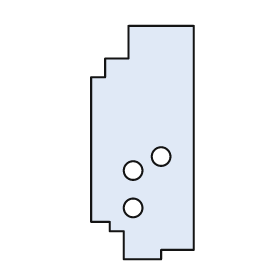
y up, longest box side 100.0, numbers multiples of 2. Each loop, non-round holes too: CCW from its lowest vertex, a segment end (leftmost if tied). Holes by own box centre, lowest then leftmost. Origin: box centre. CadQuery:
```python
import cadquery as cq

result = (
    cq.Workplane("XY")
    .moveTo(-8.0, -50.0)
    .lineTo(8.0, -50.0)
    .lineTo(8.0, -46.0)
    .lineTo(22.0, -46.0)
    .lineTo(22.0, 50.0)
    .lineTo(-6.0, 50.0)
    .lineTo(-6.0, 36.0)
    .lineTo(-16.0, 36.0)
    .lineTo(-16.0, 28.0)
    .lineTo(-22.0, 28.0)
    .lineTo(-22.0, -34.0)
    .lineTo(-14.0, -34.0)
    .lineTo(-14.0, -38.0)
    .lineTo(-8.0, -38.0)
    .close()
    .moveTo(-4.0, -28.0)
    .circle(4.0)
    .moveTo(-4.0, -12.0)
    .circle(4.0)
    .moveTo(8.0, -6.0)
    .circle(4.0)
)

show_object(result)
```